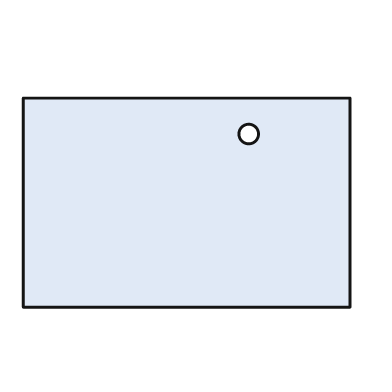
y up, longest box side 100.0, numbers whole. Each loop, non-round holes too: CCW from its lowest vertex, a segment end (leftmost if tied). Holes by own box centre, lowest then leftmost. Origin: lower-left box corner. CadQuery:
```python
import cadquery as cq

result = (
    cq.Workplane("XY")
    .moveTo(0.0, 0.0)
    .lineTo(100.0, 0.0)
    .lineTo(100.0, 64.0)
    .lineTo(0.0, 64.0)
    .close()
    .moveTo(69.0, 53.0)
    .circle(3.0)
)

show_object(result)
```